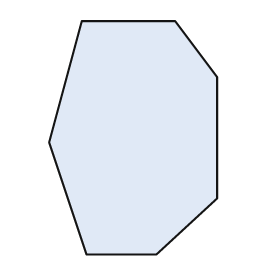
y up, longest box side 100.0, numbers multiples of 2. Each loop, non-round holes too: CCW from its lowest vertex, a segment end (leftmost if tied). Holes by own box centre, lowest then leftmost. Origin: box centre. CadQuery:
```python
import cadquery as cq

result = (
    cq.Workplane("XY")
    .moveTo(-20.0, -50.0)
    .lineTo(10.0, -50.0)
    .lineTo(36.0, -26.0)
    .lineTo(36.0, 26.0)
    .lineTo(18.0, 50.0)
    .lineTo(-22.0, 50.0)
    .lineTo(-36.0, -2.0)
    .close()
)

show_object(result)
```